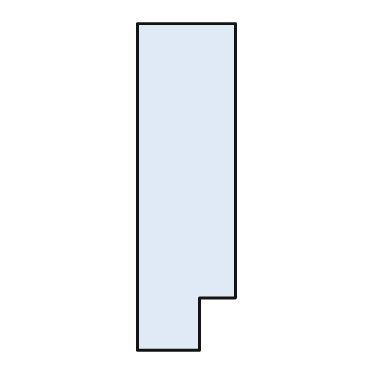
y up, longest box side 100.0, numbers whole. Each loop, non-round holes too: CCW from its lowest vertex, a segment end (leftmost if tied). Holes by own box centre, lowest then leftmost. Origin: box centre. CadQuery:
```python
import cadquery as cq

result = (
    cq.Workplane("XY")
    .moveTo(-15.0, -50.0)
    .lineTo(4.0, -50.0)
    .lineTo(4.0, -34.0)
    .lineTo(15.0, -34.0)
    .lineTo(15.0, 50.0)
    .lineTo(-15.0, 50.0)
    .close()
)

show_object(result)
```